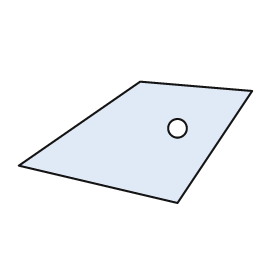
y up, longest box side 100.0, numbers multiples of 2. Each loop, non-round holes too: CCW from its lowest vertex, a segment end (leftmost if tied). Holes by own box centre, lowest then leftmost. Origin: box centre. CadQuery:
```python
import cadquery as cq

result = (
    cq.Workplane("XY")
    .moveTo(18.0, -26.0)
    .lineTo(50.0, 22.0)
    .lineTo(2.0, 26.0)
    .lineTo(-50.0, -10.0)
    .close()
    .moveTo(18.0, 6.0)
    .circle(4.0)
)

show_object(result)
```